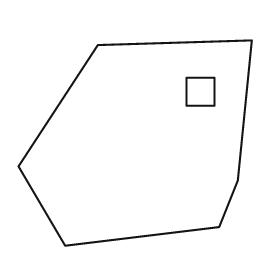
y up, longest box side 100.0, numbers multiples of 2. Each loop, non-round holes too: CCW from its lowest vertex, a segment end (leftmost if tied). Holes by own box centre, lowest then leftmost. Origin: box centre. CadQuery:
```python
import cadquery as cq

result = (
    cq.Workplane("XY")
    .moveTo(-30.0, -44.0)
    .lineTo(36.0, -36.0)
    .lineTo(44.0, -16.0)
    .lineTo(50.0, 44.0)
    .lineTo(-16.0, 42.0)
    .lineTo(-50.0, -10.0)
    .close()
    .moveTo(22.0, 16.0)
    .lineTo(34.0, 16.0)
    .lineTo(34.0, 28.0)
    .lineTo(22.0, 28.0)
    .close()
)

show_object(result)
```